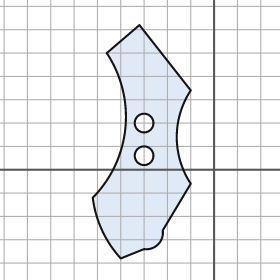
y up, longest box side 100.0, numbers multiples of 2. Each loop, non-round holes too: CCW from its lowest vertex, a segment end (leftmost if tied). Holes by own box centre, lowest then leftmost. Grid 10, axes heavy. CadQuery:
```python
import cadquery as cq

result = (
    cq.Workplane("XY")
    .moveTo(-40.0, -38.0)
    .lineTo(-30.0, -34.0)
    .threePointArc((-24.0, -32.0), (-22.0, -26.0))
    .lineTo(-10.0, -6.0)
    .threePointArc((-16.0, 14.0), (-10.0, 34.0))
    .lineTo(-32.0, 62.0)
    .lineTo(-46.0, 50.0)
    .threePointArc((-38.0, 18.0), (-52.0, -12.0))
    .threePointArc((-48.0, -26.0), (-40.0, -38.0))
    .close()
    .moveTo(-30.0, 6.0)
    .circle(4.0)
    .moveTo(-30.0, 20.0)
    .circle(4.0)
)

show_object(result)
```